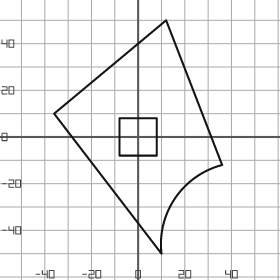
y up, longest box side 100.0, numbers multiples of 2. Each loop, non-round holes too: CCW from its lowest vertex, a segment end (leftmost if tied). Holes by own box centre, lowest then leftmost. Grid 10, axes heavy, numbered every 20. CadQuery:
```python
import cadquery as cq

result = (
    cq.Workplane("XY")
    .moveTo(10.0, -50.0)
    .threePointArc((16.0, -26.0), (36.0, -12.0))
    .lineTo(12.0, 50.0)
    .lineTo(-36.0, 10.0)
    .close()
    .moveTo(-8.0, -8.0)
    .lineTo(8.0, -8.0)
    .lineTo(8.0, 8.0)
    .lineTo(-8.0, 8.0)
    .close()
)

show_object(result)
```